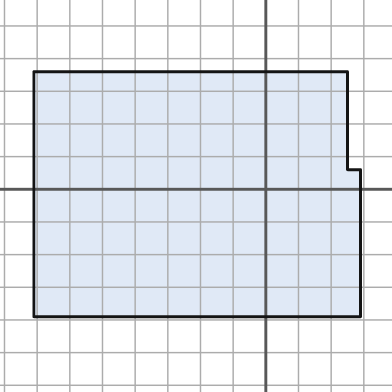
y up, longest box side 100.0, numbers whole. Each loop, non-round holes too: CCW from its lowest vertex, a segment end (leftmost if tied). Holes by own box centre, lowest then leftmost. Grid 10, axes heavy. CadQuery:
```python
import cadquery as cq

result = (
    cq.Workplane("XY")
    .moveTo(-71.0, -39.0)
    .lineTo(29.0, -39.0)
    .lineTo(29.0, 6.0)
    .lineTo(25.0, 6.0)
    .lineTo(25.0, 36.0)
    .lineTo(-71.0, 36.0)
    .close()
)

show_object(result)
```